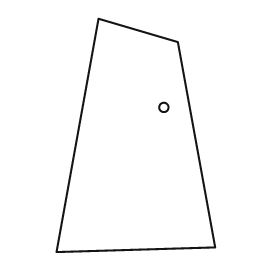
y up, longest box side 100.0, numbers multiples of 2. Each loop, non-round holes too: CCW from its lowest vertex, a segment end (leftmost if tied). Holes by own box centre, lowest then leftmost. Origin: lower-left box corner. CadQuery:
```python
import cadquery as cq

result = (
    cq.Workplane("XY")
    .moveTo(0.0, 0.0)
    .lineTo(68.0, 2.0)
    .lineTo(52.0, 90.0)
    .lineTo(18.0, 100.0)
    .close()
    .moveTo(46.0, 62.0)
    .circle(2.0)
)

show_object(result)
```